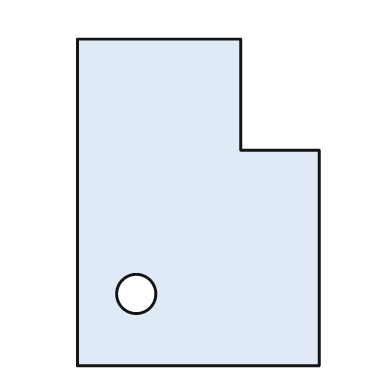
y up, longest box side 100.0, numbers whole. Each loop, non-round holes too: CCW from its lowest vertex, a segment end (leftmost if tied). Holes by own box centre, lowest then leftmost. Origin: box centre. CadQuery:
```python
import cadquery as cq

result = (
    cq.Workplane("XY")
    .moveTo(-37.0, -50.0)
    .lineTo(37.0, -50.0)
    .lineTo(37.0, 16.0)
    .lineTo(13.0, 16.0)
    .lineTo(13.0, 50.0)
    .lineTo(-37.0, 50.0)
    .close()
    .moveTo(-19.0, -28.0)
    .circle(6.0)
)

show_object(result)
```